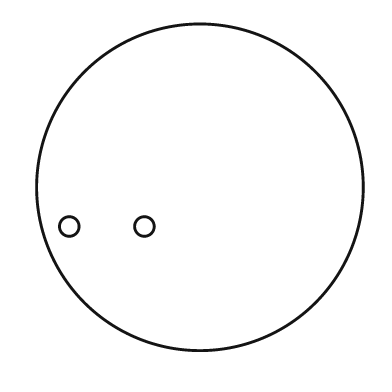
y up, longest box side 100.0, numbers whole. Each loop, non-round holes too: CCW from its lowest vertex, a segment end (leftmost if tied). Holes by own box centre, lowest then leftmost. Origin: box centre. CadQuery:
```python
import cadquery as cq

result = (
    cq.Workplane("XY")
    .moveTo(0.0, 0.0)
    .circle(50.0)
    .moveTo(-40.0, -12.0)
    .circle(3.0)
    .moveTo(-17.0, -12.0)
    .circle(3.0)
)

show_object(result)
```